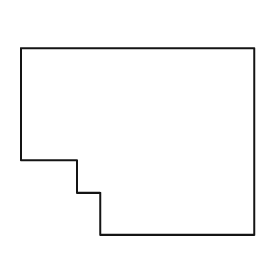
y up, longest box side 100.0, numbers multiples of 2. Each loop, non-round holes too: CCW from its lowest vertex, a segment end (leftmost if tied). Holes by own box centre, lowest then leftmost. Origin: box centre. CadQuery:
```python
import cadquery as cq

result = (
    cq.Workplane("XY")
    .moveTo(-16.0, -40.0)
    .lineTo(50.0, -40.0)
    .lineTo(50.0, 40.0)
    .lineTo(-50.0, 40.0)
    .lineTo(-50.0, -8.0)
    .lineTo(-26.0, -8.0)
    .lineTo(-26.0, -22.0)
    .lineTo(-16.0, -22.0)
    .close()
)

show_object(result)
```